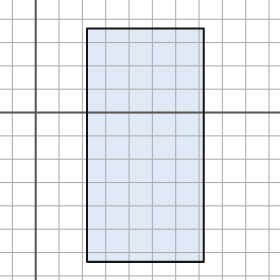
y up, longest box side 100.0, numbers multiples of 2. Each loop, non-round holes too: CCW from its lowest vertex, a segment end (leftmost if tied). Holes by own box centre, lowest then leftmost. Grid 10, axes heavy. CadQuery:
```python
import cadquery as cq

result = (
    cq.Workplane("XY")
    .moveTo(22.0, -64.0)
    .lineTo(72.0, -64.0)
    .lineTo(72.0, 36.0)
    .lineTo(22.0, 36.0)
    .close()
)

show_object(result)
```